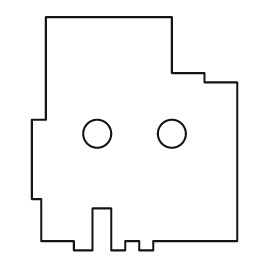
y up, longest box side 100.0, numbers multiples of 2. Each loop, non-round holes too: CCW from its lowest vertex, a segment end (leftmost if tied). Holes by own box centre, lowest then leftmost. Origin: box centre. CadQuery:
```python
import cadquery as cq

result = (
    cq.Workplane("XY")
    .moveTo(-26.0, -50.0)
    .lineTo(-18.0, -50.0)
    .lineTo(-18.0, -32.0)
    .lineTo(-10.0, -32.0)
    .lineTo(-10.0, -50.0)
    .lineTo(-4.0, -50.0)
    .lineTo(-4.0, -46.0)
    .lineTo(2.0, -46.0)
    .lineTo(2.0, -50.0)
    .lineTo(8.0, -50.0)
    .lineTo(8.0, -46.0)
    .lineTo(44.0, -46.0)
    .lineTo(44.0, 22.0)
    .lineTo(30.0, 22.0)
    .lineTo(30.0, 26.0)
    .lineTo(16.0, 26.0)
    .lineTo(16.0, 50.0)
    .lineTo(-38.0, 50.0)
    .lineTo(-38.0, 6.0)
    .lineTo(-44.0, 6.0)
    .lineTo(-44.0, -28.0)
    .lineTo(-40.0, -28.0)
    .lineTo(-40.0, -46.0)
    .lineTo(-26.0, -46.0)
    .close()
    .moveTo(-16.0, 0.0)
    .circle(6.0)
    .moveTo(16.0, 0.0)
    .circle(6.0)
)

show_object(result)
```